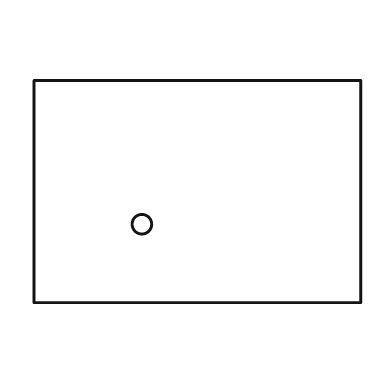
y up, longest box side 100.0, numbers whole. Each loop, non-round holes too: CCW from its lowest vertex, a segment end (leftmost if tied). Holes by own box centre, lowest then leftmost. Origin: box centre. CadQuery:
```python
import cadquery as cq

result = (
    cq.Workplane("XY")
    .moveTo(-50.0, -34.0)
    .lineTo(50.0, -34.0)
    .lineTo(50.0, 34.0)
    .lineTo(-50.0, 34.0)
    .close()
    .moveTo(-17.0, -10.0)
    .circle(3.0)
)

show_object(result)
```